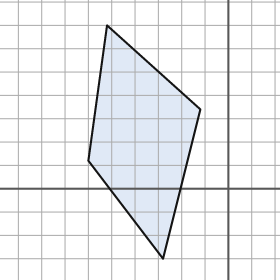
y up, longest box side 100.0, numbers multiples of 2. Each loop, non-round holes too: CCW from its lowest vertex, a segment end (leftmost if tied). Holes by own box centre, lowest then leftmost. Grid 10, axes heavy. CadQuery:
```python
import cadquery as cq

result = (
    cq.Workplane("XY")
    .moveTo(-28.0, -30.0)
    .lineTo(-12.0, 34.0)
    .lineTo(-52.0, 70.0)
    .lineTo(-60.0, 12.0)
    .close()
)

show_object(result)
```